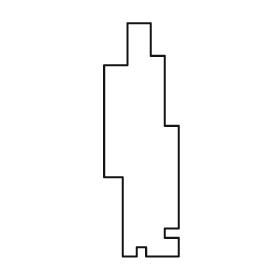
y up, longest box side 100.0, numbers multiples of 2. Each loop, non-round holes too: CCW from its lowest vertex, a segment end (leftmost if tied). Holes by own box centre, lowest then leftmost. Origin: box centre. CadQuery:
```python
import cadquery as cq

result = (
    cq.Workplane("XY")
    .moveTo(-8.0, -50.0)
    .lineTo(-2.0, -50.0)
    .lineTo(-2.0, -46.0)
    .lineTo(2.0, -46.0)
    .lineTo(2.0, -50.0)
    .lineTo(16.0, -50.0)
    .lineTo(16.0, -42.0)
    .lineTo(10.0, -42.0)
    .lineTo(10.0, -38.0)
    .lineTo(16.0, -38.0)
    .lineTo(16.0, 6.0)
    .lineTo(10.0, 6.0)
    .lineTo(10.0, 36.0)
    .lineTo(4.0, 36.0)
    .lineTo(4.0, 50.0)
    .lineTo(-6.0, 50.0)
    .lineTo(-6.0, 32.0)
    .lineTo(-16.0, 32.0)
    .lineTo(-16.0, -16.0)
    .lineTo(-8.0, -16.0)
    .close()
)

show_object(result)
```